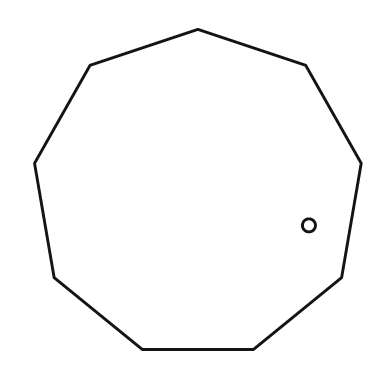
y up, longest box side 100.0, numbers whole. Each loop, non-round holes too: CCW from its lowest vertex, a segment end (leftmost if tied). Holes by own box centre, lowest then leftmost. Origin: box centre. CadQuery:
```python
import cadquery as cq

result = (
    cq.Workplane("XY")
    .moveTo(-17.0, -49.0)
    .lineTo(17.0, -49.0)
    .lineTo(44.0, -27.0)
    .lineTo(50.0, 8.0)
    .lineTo(33.0, 38.0)
    .lineTo(0.0, 49.0)
    .lineTo(-33.0, 38.0)
    .lineTo(-50.0, 8.0)
    .lineTo(-44.0, -27.0)
    .close()
    .moveTo(34.0, -11.0)
    .circle(2.0)
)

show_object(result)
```